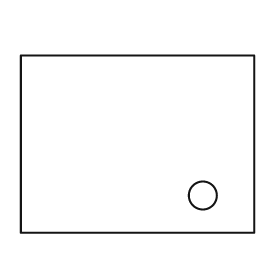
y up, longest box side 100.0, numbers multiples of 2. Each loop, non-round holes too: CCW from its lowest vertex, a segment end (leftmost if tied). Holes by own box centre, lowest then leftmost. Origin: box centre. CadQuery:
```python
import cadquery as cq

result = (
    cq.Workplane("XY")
    .moveTo(-50.0, -38.0)
    .lineTo(50.0, -38.0)
    .lineTo(50.0, 38.0)
    .lineTo(-50.0, 38.0)
    .close()
    .moveTo(28.0, -22.0)
    .circle(6.0)
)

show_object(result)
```